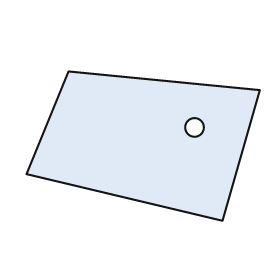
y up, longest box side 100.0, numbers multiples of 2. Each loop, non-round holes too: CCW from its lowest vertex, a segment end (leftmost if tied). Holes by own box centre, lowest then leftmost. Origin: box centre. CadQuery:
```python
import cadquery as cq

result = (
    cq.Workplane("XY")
    .moveTo(34.0, -32.0)
    .lineTo(50.0, 24.0)
    .lineTo(-32.0, 32.0)
    .lineTo(-50.0, -12.0)
    .close()
    .moveTo(22.0, 8.0)
    .circle(4.0)
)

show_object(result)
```